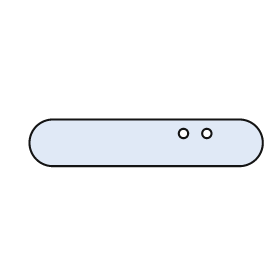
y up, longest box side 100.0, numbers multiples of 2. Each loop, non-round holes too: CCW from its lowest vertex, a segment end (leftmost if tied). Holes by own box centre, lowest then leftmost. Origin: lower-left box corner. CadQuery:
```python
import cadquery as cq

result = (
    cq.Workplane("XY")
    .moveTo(10.0, 0.0)
    .lineTo(90.0, 0.0)
    .threePointArc((100.0, 10.0), (90.0, 20.0))
    .lineTo(10.0, 20.0)
    .threePointArc((0.0, 10.0), (10.0, 0.0))
    .close()
    .moveTo(66.0, 14.0)
    .circle(2.0)
    .moveTo(76.0, 14.0)
    .circle(2.0)
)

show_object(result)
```